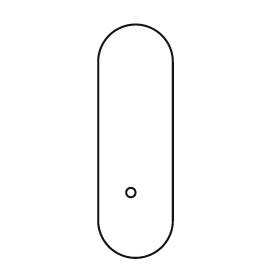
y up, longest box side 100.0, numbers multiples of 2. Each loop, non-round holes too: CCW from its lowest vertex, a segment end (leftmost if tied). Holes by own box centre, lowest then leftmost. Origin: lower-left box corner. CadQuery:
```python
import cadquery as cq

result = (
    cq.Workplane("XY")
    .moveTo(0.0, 16.0)
    .threePointArc((16.0, 0.0), (32.0, 16.0))
    .lineTo(32.0, 84.0)
    .threePointArc((16.0, 100.0), (0.0, 84.0))
    .close()
    .moveTo(14.0, 28.0)
    .circle(2.0)
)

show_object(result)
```